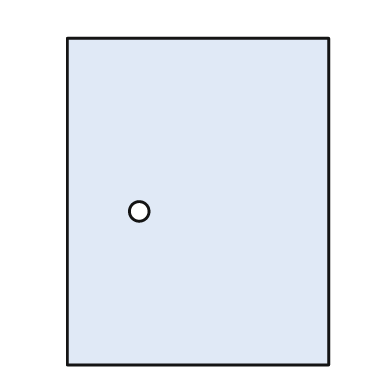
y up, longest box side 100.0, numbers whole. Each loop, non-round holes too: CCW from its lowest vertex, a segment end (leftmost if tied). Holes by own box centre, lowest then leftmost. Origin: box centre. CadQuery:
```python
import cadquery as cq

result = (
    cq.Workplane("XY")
    .moveTo(-40.0, -50.0)
    .lineTo(40.0, -50.0)
    .lineTo(40.0, 50.0)
    .lineTo(-40.0, 50.0)
    .close()
    .moveTo(-18.0, -3.0)
    .circle(3.0)
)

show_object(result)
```